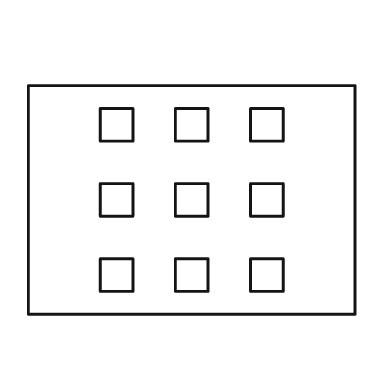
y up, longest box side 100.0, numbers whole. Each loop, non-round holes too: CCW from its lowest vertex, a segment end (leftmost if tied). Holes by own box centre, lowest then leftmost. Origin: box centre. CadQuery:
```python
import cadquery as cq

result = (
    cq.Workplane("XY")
    .moveTo(-50.0, -35.0)
    .lineTo(50.0, -35.0)
    .lineTo(50.0, 35.0)
    .lineTo(-50.0, 35.0)
    .close()
    .moveTo(-28.0, -28.0)
    .lineTo(-18.0, -28.0)
    .lineTo(-18.0, -18.0)
    .lineTo(-28.0, -18.0)
    .close()
    .moveTo(-5.0, -28.0)
    .lineTo(5.0, -28.0)
    .lineTo(5.0, -18.0)
    .lineTo(-5.0, -18.0)
    .close()
    .moveTo(18.0, -28.0)
    .lineTo(28.0, -28.0)
    .lineTo(28.0, -18.0)
    .lineTo(18.0, -18.0)
    .close()
    .moveTo(-28.0, -5.0)
    .lineTo(-18.0, -5.0)
    .lineTo(-18.0, 5.0)
    .lineTo(-28.0, 5.0)
    .close()
    .moveTo(-5.0, -5.0)
    .lineTo(5.0, -5.0)
    .lineTo(5.0, 5.0)
    .lineTo(-5.0, 5.0)
    .close()
    .moveTo(18.0, -5.0)
    .lineTo(28.0, -5.0)
    .lineTo(28.0, 5.0)
    .lineTo(18.0, 5.0)
    .close()
    .moveTo(-28.0, 18.0)
    .lineTo(-18.0, 18.0)
    .lineTo(-18.0, 28.0)
    .lineTo(-28.0, 28.0)
    .close()
    .moveTo(-5.0, 18.0)
    .lineTo(5.0, 18.0)
    .lineTo(5.0, 28.0)
    .lineTo(-5.0, 28.0)
    .close()
    .moveTo(18.0, 18.0)
    .lineTo(28.0, 18.0)
    .lineTo(28.0, 28.0)
    .lineTo(18.0, 28.0)
    .close()
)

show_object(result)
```